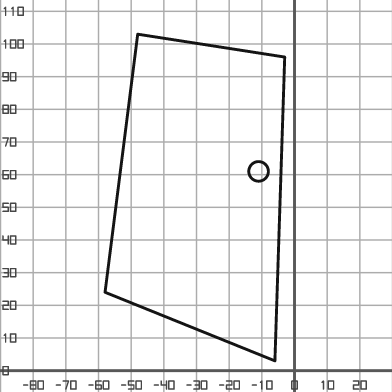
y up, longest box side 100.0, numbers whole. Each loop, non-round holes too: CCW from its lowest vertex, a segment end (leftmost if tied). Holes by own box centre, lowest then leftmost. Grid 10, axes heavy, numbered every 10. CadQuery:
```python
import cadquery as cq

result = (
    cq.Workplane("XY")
    .moveTo(-6.0, 3.0)
    .lineTo(-3.0, 96.0)
    .lineTo(-48.0, 103.0)
    .lineTo(-58.0, 24.0)
    .close()
    .moveTo(-11.0, 61.0)
    .circle(3.0)
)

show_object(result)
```